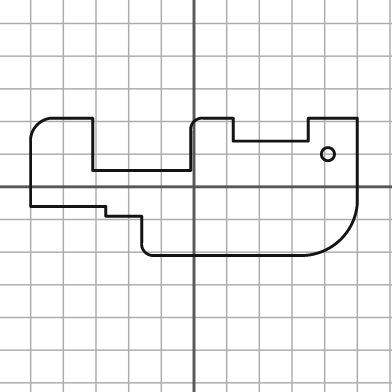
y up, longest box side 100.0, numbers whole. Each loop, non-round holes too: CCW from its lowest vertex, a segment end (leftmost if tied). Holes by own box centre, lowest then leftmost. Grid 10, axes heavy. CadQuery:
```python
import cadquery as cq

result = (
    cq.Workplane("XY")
    .moveTo(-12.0, -21.0)
    .lineTo(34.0, -21.0)
    .threePointArc((45.0, -16.0), (50.0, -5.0))
    .lineTo(50.0, 21.0)
    .lineTo(35.0, 21.0)
    .lineTo(35.0, 14.0)
    .lineTo(12.0, 14.0)
    .lineTo(12.0, 21.0)
    .lineTo(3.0, 21.0)
    .threePointArc((0.0, 20.0), (-1.0, 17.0))
    .lineTo(-1.0, 5.0)
    .lineTo(-31.0, 5.0)
    .lineTo(-31.0, 21.0)
    .lineTo(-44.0, 21.0)
    .threePointArc((-48.0, 19.0), (-50.0, 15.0))
    .lineTo(-50.0, -6.0)
    .lineTo(-27.0, -6.0)
    .lineTo(-27.0, -9.0)
    .lineTo(-16.0, -9.0)
    .lineTo(-16.0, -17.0)
    .threePointArc((-15.0, -20.0), (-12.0, -21.0))
    .close()
    .moveTo(41.0, 10.0)
    .circle(2.0)
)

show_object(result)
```